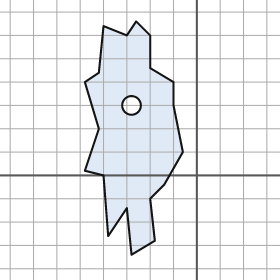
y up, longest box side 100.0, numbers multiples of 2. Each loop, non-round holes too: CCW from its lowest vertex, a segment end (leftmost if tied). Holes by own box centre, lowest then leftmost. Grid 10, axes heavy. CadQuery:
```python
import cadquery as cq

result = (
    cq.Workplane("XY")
    .moveTo(-28.0, -34.0)
    .lineTo(-18.0, -28.0)
    .lineTo(-20.0, -10.0)
    .lineTo(-14.0, -4.0)
    .lineTo(-6.0, 10.0)
    .lineTo(-10.0, 30.0)
    .lineTo(-10.0, 40.0)
    .lineTo(-20.0, 46.0)
    .lineTo(-20.0, 60.0)
    .lineTo(-26.0, 66.0)
    .lineTo(-30.0, 60.0)
    .lineTo(-40.0, 64.0)
    .lineTo(-42.0, 44.0)
    .lineTo(-48.0, 40.0)
    .lineTo(-42.0, 20.0)
    .lineTo(-48.0, 2.0)
    .lineTo(-40.0, 0.0)
    .lineTo(-38.0, -26.0)
    .lineTo(-30.0, -14.0)
    .close()
    .moveTo(-28.0, 30.0)
    .circle(4.0)
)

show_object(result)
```